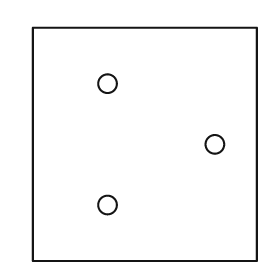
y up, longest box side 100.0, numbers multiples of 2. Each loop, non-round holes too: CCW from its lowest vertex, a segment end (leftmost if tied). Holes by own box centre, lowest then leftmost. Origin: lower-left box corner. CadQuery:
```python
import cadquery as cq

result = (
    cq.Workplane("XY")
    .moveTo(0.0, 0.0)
    .lineTo(96.0, 0.0)
    .lineTo(96.0, 100.0)
    .lineTo(0.0, 100.0)
    .close()
    .moveTo(32.0, 24.0)
    .circle(4.0)
    .moveTo(78.0, 50.0)
    .circle(4.0)
    .moveTo(32.0, 76.0)
    .circle(4.0)
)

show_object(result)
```